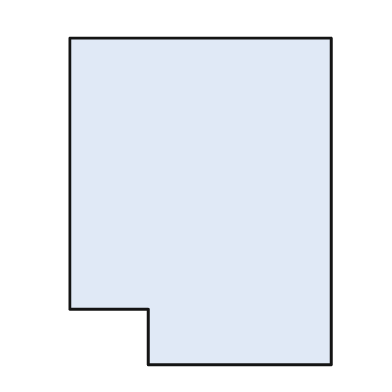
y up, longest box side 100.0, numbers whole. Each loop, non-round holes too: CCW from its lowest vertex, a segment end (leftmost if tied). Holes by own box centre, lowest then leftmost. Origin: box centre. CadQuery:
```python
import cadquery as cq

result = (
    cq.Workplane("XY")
    .moveTo(-16.0, -50.0)
    .lineTo(40.0, -50.0)
    .lineTo(40.0, 50.0)
    .lineTo(-40.0, 50.0)
    .lineTo(-40.0, -33.0)
    .lineTo(-16.0, -33.0)
    .close()
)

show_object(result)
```